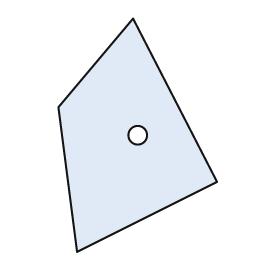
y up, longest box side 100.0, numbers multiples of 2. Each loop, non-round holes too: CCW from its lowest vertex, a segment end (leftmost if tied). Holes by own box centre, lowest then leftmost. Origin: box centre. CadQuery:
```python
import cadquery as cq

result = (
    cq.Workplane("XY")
    .moveTo(-26.0, -50.0)
    .lineTo(34.0, -20.0)
    .lineTo(-2.0, 50.0)
    .lineTo(-34.0, 12.0)
    .close()
    .moveTo(0.0, 0.0)
    .circle(4.0)
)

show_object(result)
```